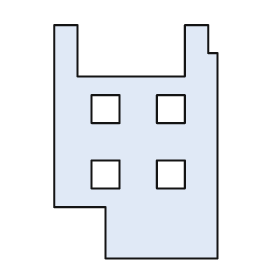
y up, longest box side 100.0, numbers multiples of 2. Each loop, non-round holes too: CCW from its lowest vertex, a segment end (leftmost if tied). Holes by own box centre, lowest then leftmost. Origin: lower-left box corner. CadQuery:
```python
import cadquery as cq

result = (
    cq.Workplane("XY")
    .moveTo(22.0, 0.0)
    .lineTo(70.0, 0.0)
    .lineTo(70.0, 88.0)
    .lineTo(66.0, 88.0)
    .lineTo(66.0, 100.0)
    .lineTo(56.0, 100.0)
    .lineTo(56.0, 78.0)
    .lineTo(10.0, 78.0)
    .lineTo(10.0, 100.0)
    .lineTo(0.0, 100.0)
    .lineTo(0.0, 22.0)
    .lineTo(22.0, 22.0)
    .close()
    .moveTo(16.0, 30.0)
    .lineTo(28.0, 30.0)
    .lineTo(28.0, 42.0)
    .lineTo(16.0, 42.0)
    .close()
    .moveTo(44.0, 30.0)
    .lineTo(56.0, 30.0)
    .lineTo(56.0, 42.0)
    .lineTo(44.0, 42.0)
    .close()
    .moveTo(16.0, 58.0)
    .lineTo(28.0, 58.0)
    .lineTo(28.0, 70.0)
    .lineTo(16.0, 70.0)
    .close()
    .moveTo(44.0, 58.0)
    .lineTo(56.0, 58.0)
    .lineTo(56.0, 70.0)
    .lineTo(44.0, 70.0)
    .close()
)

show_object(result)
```